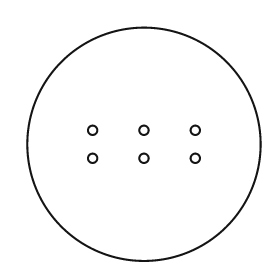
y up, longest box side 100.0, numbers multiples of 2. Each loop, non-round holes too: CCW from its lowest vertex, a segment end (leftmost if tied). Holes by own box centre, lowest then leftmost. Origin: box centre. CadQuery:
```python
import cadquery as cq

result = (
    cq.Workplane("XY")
    .moveTo(0.0, 0.0)
    .circle(50.0)
    .moveTo(-22.0, -6.0)
    .circle(2.0)
    .moveTo(0.0, -6.0)
    .circle(2.0)
    .moveTo(22.0, -6.0)
    .circle(2.0)
    .moveTo(-22.0, 6.0)
    .circle(2.0)
    .moveTo(0.0, 6.0)
    .circle(2.0)
    .moveTo(22.0, 6.0)
    .circle(2.0)
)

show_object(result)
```